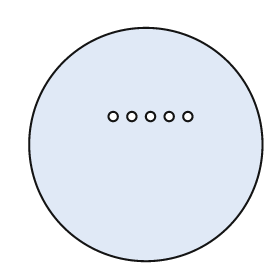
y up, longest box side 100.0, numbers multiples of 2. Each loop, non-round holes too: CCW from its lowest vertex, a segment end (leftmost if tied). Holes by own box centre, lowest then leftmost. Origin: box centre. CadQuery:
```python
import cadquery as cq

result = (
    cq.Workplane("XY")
    .moveTo(0.0, 0.0)
    .circle(50.0)
    .moveTo(-14.0, 12.0)
    .circle(2.0)
    .moveTo(-6.0, 12.0)
    .circle(2.0)
    .moveTo(2.0, 12.0)
    .circle(2.0)
    .moveTo(10.0, 12.0)
    .circle(2.0)
    .moveTo(18.0, 12.0)
    .circle(2.0)
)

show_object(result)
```